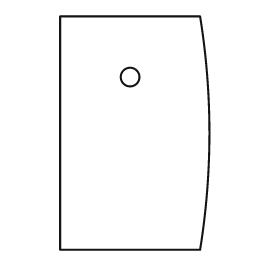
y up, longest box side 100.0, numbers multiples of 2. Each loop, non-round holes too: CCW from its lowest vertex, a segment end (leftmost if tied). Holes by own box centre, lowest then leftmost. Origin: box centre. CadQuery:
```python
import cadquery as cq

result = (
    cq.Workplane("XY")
    .moveTo(-32.0, -50.0)
    .lineTo(28.0, -50.0)
    .threePointArc((32.0, 0.0), (28.0, 50.0))
    .lineTo(-32.0, 50.0)
    .close()
    .moveTo(-2.0, 24.0)
    .circle(4.0)
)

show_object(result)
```